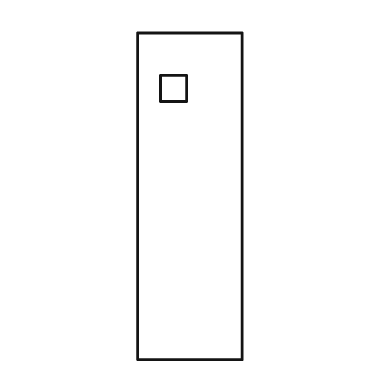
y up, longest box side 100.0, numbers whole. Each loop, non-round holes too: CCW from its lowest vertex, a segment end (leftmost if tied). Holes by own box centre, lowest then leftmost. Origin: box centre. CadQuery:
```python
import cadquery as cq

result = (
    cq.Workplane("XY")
    .moveTo(-16.0, -50.0)
    .lineTo(16.0, -50.0)
    .lineTo(16.0, 50.0)
    .lineTo(-16.0, 50.0)
    .close()
    .moveTo(-9.0, 29.0)
    .lineTo(-1.0, 29.0)
    .lineTo(-1.0, 37.0)
    .lineTo(-9.0, 37.0)
    .close()
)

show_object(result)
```